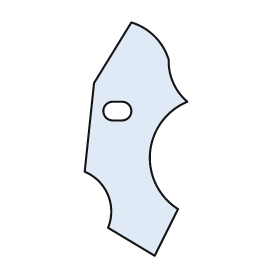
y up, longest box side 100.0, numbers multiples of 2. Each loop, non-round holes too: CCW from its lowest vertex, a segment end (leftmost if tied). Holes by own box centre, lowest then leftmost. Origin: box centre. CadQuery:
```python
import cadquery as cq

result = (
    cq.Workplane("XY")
    .moveTo(8.0, -50.0)
    .lineTo(18.0, -30.0)
    .threePointArc((6.0, -6.0), (22.0, 16.0))
    .threePointArc((16.0, 24.0), (14.0, 34.0))
    .threePointArc((8.0, 44.0), (-2.0, 50.0))
    .lineTo(-18.0, 24.0)
    .lineTo(-22.0, -14.0)
    .threePointArc((-12.0, -24.0), (-12.0, -38.0))
    .close()
    .moveTo(-10.0, 8.0)
    .lineTo(-6.0, 8.0)
    .threePointArc((-2.0, 12.0), (-6.0, 16.0))
    .lineTo(-10.0, 16.0)
    .threePointArc((-14.0, 12.0), (-10.0, 8.0))
    .close()
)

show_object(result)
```